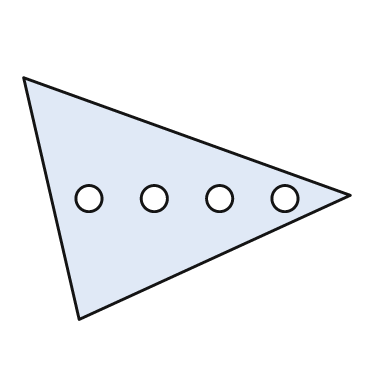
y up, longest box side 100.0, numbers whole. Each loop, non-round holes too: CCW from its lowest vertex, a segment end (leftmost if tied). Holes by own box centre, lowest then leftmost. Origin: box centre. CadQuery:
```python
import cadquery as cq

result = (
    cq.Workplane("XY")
    .moveTo(-33.0, -37.0)
    .lineTo(50.0, 1.0)
    .lineTo(-50.0, 37.0)
    .close()
    .moveTo(-30.0, 0.0)
    .circle(4.0)
    .moveTo(-10.0, 0.0)
    .circle(4.0)
    .moveTo(10.0, 0.0)
    .circle(4.0)
    .moveTo(30.0, 0.0)
    .circle(4.0)
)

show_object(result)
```